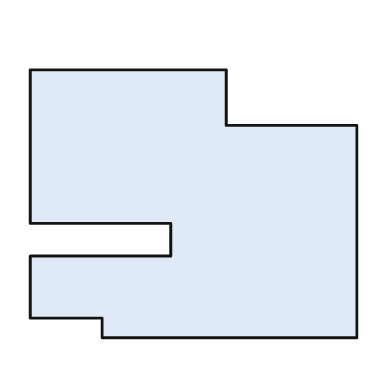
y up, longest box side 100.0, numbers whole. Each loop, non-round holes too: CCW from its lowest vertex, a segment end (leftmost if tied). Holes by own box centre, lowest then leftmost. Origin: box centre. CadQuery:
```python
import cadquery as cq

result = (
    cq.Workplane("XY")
    .moveTo(-28.0, -41.0)
    .lineTo(50.0, -41.0)
    .lineTo(50.0, 24.0)
    .lineTo(10.0, 24.0)
    .lineTo(10.0, 41.0)
    .lineTo(-50.0, 41.0)
    .lineTo(-50.0, -6.0)
    .lineTo(-7.0, -6.0)
    .lineTo(-7.0, -16.0)
    .lineTo(-50.0, -16.0)
    .lineTo(-50.0, -35.0)
    .lineTo(-28.0, -35.0)
    .close()
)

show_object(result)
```